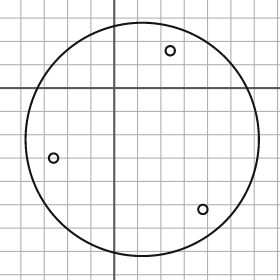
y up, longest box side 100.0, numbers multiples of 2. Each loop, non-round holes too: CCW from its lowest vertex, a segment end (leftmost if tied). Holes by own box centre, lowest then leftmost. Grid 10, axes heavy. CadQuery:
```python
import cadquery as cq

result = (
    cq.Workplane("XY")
    .moveTo(12.0, -22.0)
    .circle(50.0)
    .moveTo(38.0, -52.0)
    .circle(2.0)
    .moveTo(-26.0, -30.0)
    .circle(2.0)
    .moveTo(24.0, 16.0)
    .circle(2.0)
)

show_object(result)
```